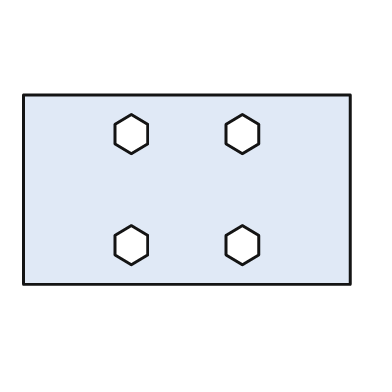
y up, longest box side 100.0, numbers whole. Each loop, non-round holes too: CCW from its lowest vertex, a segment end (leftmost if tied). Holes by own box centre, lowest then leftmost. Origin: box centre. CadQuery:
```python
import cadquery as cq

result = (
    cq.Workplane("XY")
    .moveTo(-50.0, -29.0)
    .lineTo(50.0, -29.0)
    .lineTo(50.0, 29.0)
    .lineTo(-50.0, 29.0)
    .close()
    .moveTo(-17.0, -23.0)
    .lineTo(-12.0, -20.0)
    .lineTo(-12.0, -14.0)
    .lineTo(-17.0, -11.0)
    .lineTo(-22.0, -14.0)
    .lineTo(-22.0, -20.0)
    .close()
    .moveTo(17.0, -23.0)
    .lineTo(22.0, -20.0)
    .lineTo(22.0, -14.0)
    .lineTo(17.0, -11.0)
    .lineTo(12.0, -14.0)
    .lineTo(12.0, -20.0)
    .close()
    .moveTo(-17.0, 11.0)
    .lineTo(-12.0, 14.0)
    .lineTo(-12.0, 20.0)
    .lineTo(-17.0, 23.0)
    .lineTo(-22.0, 20.0)
    .lineTo(-22.0, 14.0)
    .close()
    .moveTo(17.0, 11.0)
    .lineTo(22.0, 14.0)
    .lineTo(22.0, 20.0)
    .lineTo(17.0, 23.0)
    .lineTo(12.0, 20.0)
    .lineTo(12.0, 14.0)
    .close()
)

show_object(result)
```